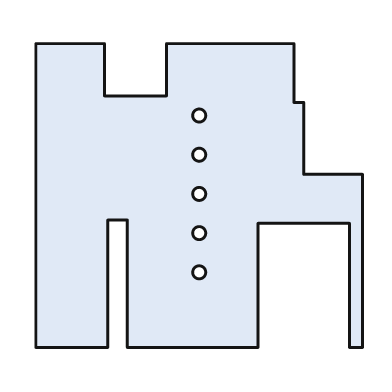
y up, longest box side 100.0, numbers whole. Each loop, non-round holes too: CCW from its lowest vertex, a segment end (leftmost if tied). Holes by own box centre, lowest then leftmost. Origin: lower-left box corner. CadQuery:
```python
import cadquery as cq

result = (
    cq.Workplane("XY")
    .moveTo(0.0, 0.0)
    .lineTo(22.0, 0.0)
    .lineTo(22.0, 39.0)
    .lineTo(28.0, 39.0)
    .lineTo(28.0, 0.0)
    .lineTo(68.0, 0.0)
    .lineTo(68.0, 38.0)
    .lineTo(96.0, 38.0)
    .lineTo(96.0, 0.0)
    .lineTo(100.0, 0.0)
    .lineTo(100.0, 53.0)
    .lineTo(82.0, 53.0)
    .lineTo(82.0, 75.0)
    .lineTo(79.0, 75.0)
    .lineTo(79.0, 93.0)
    .lineTo(40.0, 93.0)
    .lineTo(40.0, 77.0)
    .lineTo(21.0, 77.0)
    .lineTo(21.0, 93.0)
    .lineTo(0.0, 93.0)
    .close()
    .moveTo(50.0, 23.0)
    .circle(2.0)
    .moveTo(50.0, 35.0)
    .circle(2.0)
    .moveTo(50.0, 47.0)
    .circle(2.0)
    .moveTo(50.0, 59.0)
    .circle(2.0)
    .moveTo(50.0, 71.0)
    .circle(2.0)
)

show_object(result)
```